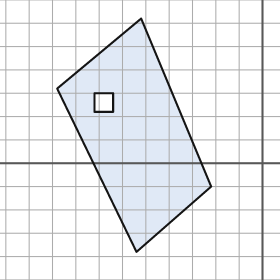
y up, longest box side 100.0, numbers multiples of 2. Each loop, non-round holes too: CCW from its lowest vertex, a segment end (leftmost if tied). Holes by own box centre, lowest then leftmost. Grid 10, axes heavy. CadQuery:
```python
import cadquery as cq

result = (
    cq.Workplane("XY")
    .moveTo(-54.0, -38.0)
    .lineTo(-22.0, -10.0)
    .lineTo(-52.0, 62.0)
    .lineTo(-88.0, 32.0)
    .close()
    .moveTo(-72.0, 22.0)
    .lineTo(-64.0, 22.0)
    .lineTo(-64.0, 30.0)
    .lineTo(-72.0, 30.0)
    .close()
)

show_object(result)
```